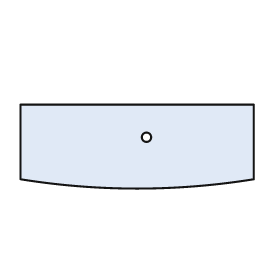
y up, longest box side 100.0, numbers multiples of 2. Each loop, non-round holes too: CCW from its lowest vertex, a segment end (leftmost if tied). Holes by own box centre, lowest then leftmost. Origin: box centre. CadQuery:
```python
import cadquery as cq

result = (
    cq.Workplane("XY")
    .moveTo(-50.0, -14.0)
    .threePointArc((0.0, -18.0), (50.0, -14.0))
    .lineTo(50.0, 18.0)
    .lineTo(-50.0, 18.0)
    .close()
    .moveTo(4.0, 4.0)
    .circle(2.0)
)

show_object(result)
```